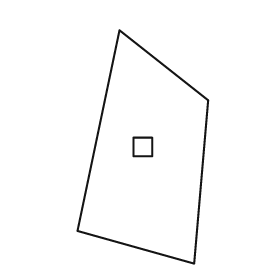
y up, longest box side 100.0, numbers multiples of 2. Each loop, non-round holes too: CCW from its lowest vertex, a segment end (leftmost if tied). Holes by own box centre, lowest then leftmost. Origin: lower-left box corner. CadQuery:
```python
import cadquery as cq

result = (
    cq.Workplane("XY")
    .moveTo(50.0, 0.0)
    .lineTo(56.0, 70.0)
    .lineTo(18.0, 100.0)
    .lineTo(0.0, 14.0)
    .close()
    .moveTo(24.0, 46.0)
    .lineTo(32.0, 46.0)
    .lineTo(32.0, 54.0)
    .lineTo(24.0, 54.0)
    .close()
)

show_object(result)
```